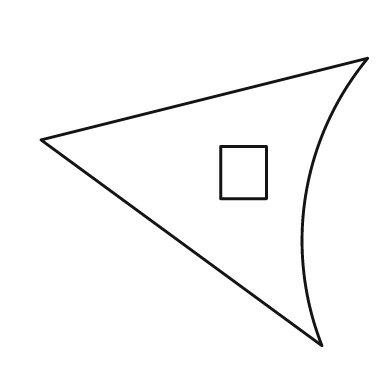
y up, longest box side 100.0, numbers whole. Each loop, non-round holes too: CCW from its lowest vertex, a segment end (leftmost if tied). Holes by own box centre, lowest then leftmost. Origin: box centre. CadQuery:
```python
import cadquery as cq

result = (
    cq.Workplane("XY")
    .moveTo(36.0, -44.0)
    .threePointArc((31.0, 2.0), (50.0, 44.0))
    .lineTo(-50.0, 19.0)
    .close()
    .moveTo(5.0, 1.0)
    .lineTo(19.0, 1.0)
    .lineTo(19.0, 17.0)
    .lineTo(5.0, 17.0)
    .close()
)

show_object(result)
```